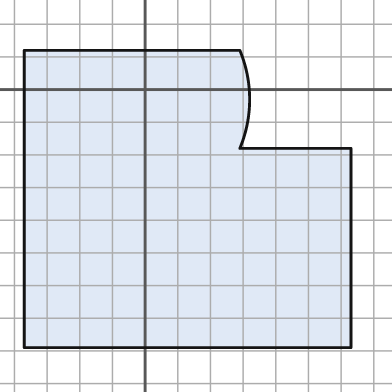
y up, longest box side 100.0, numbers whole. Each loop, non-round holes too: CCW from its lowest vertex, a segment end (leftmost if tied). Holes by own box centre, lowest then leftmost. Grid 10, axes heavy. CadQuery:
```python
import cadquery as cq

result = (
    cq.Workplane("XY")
    .moveTo(-37.0, -79.0)
    .lineTo(63.0, -79.0)
    .lineTo(63.0, -18.0)
    .lineTo(29.0, -18.0)
    .threePointArc((32.0, -3.0), (29.0, 12.0))
    .lineTo(-37.0, 12.0)
    .close()
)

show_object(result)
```